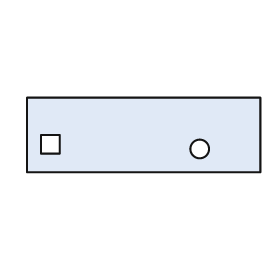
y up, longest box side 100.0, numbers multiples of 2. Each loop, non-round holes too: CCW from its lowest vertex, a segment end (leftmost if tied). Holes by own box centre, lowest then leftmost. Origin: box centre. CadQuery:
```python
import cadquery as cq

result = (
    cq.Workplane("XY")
    .moveTo(-50.0, -16.0)
    .lineTo(50.0, -16.0)
    .lineTo(50.0, 16.0)
    .lineTo(-50.0, 16.0)
    .close()
    .moveTo(24.0, -6.0)
    .circle(4.0)
    .moveTo(-44.0, -8.0)
    .lineTo(-36.0, -8.0)
    .lineTo(-36.0, 0.0)
    .lineTo(-44.0, 0.0)
    .close()
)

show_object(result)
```